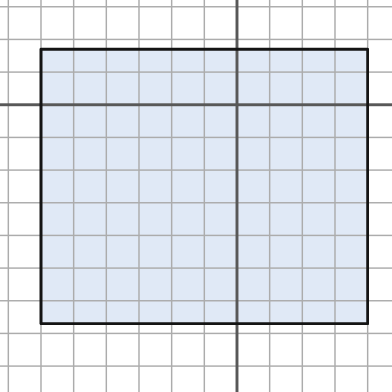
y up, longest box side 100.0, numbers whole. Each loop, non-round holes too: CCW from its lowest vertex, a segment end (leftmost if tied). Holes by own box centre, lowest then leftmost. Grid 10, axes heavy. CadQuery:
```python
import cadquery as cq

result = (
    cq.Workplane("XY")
    .moveTo(-60.0, -67.0)
    .lineTo(40.0, -67.0)
    .lineTo(40.0, 17.0)
    .lineTo(-60.0, 17.0)
    .close()
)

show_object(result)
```